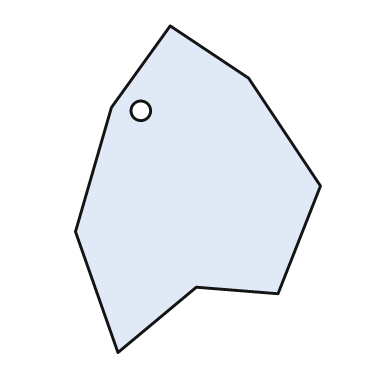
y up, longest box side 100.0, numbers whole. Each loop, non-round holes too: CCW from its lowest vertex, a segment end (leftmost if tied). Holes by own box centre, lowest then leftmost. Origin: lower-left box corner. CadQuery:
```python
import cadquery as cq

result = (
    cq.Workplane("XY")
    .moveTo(13.0, 0.0)
    .lineTo(37.0, 20.0)
    .lineTo(62.0, 18.0)
    .lineTo(75.0, 51.0)
    .lineTo(53.0, 84.0)
    .lineTo(29.0, 100.0)
    .lineTo(11.0, 75.0)
    .lineTo(0.0, 37.0)
    .close()
    .moveTo(20.0, 74.0)
    .circle(3.0)
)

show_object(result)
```